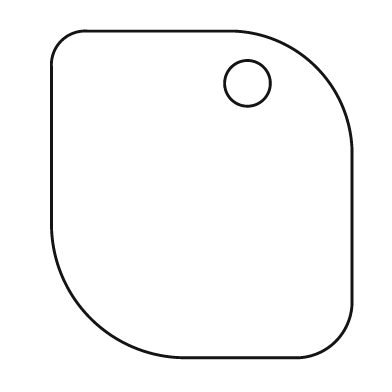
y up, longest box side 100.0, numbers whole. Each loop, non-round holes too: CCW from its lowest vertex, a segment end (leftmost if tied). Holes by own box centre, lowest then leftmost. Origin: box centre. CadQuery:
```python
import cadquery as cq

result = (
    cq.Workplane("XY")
    .moveTo(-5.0, -50.0)
    .lineTo(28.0, -50.0)
    .threePointArc((41.0, -45.0), (46.0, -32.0))
    .lineTo(46.0, 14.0)
    .threePointArc((35.0, 39.0), (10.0, 50.0))
    .lineTo(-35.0, 50.0)
    .threePointArc((-43.0, 47.0), (-46.0, 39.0))
    .lineTo(-46.0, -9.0)
    .threePointArc((-34.0, -38.0), (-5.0, -50.0))
    .close()
    .moveTo(14.0, 34.0)
    .circle(7.0)
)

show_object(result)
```